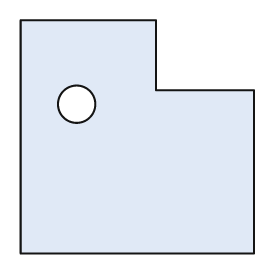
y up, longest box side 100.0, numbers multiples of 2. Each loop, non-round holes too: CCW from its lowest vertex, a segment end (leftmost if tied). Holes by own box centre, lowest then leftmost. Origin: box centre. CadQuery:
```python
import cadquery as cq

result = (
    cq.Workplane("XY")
    .moveTo(-50.0, -50.0)
    .lineTo(50.0, -50.0)
    .lineTo(50.0, 20.0)
    .lineTo(8.0, 20.0)
    .lineTo(8.0, 50.0)
    .lineTo(-50.0, 50.0)
    .close()
    .moveTo(-26.0, 14.0)
    .circle(8.0)
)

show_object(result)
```